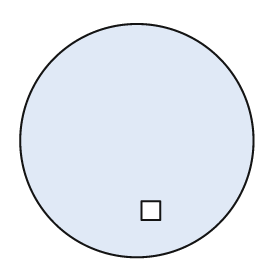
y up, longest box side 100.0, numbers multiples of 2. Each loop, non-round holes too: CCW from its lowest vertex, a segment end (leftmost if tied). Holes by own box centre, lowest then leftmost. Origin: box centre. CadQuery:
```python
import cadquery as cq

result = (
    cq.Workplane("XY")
    .moveTo(0.0, 0.0)
    .circle(50.0)
    .moveTo(2.0, -34.0)
    .lineTo(10.0, -34.0)
    .lineTo(10.0, -26.0)
    .lineTo(2.0, -26.0)
    .close()
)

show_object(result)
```